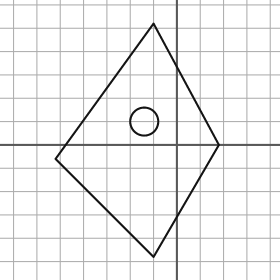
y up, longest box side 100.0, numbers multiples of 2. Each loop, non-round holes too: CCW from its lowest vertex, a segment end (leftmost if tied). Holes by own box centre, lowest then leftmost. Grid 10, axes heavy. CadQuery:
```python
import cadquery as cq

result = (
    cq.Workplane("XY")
    .moveTo(-10.0, -48.0)
    .lineTo(18.0, 0.0)
    .lineTo(-10.0, 52.0)
    .lineTo(-52.0, -6.0)
    .close()
    .moveTo(-14.0, 10.0)
    .circle(6.0)
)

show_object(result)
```